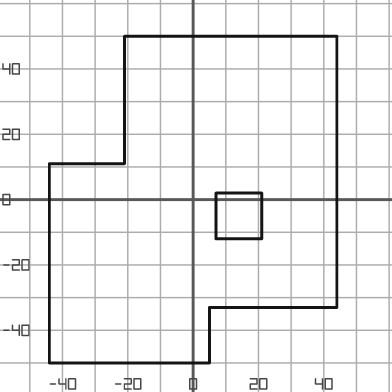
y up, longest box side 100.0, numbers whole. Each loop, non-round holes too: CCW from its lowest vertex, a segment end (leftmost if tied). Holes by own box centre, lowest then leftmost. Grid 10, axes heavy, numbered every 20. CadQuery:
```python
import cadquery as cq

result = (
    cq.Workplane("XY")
    .moveTo(-44.0, -50.0)
    .lineTo(5.0, -50.0)
    .lineTo(5.0, -33.0)
    .lineTo(44.0, -33.0)
    .lineTo(44.0, 50.0)
    .lineTo(-21.0, 50.0)
    .lineTo(-21.0, 11.0)
    .lineTo(-44.0, 11.0)
    .close()
    .moveTo(7.0, -12.0)
    .lineTo(21.0, -12.0)
    .lineTo(21.0, 2.0)
    .lineTo(7.0, 2.0)
    .close()
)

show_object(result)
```